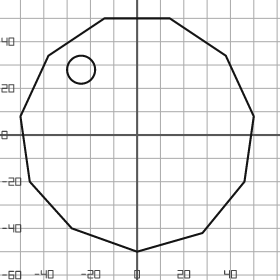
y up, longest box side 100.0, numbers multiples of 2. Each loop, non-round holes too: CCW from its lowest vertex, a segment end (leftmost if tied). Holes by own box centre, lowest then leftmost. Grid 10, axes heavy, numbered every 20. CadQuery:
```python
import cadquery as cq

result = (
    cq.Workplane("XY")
    .moveTo(0.0, -50.0)
    .lineTo(28.0, -42.0)
    .lineTo(46.0, -20.0)
    .lineTo(50.0, 8.0)
    .lineTo(38.0, 34.0)
    .lineTo(14.0, 50.0)
    .lineTo(-14.0, 50.0)
    .lineTo(-38.0, 34.0)
    .lineTo(-50.0, 8.0)
    .lineTo(-46.0, -20.0)
    .lineTo(-28.0, -40.0)
    .close()
    .moveTo(-24.0, 28.0)
    .circle(6.0)
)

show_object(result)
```